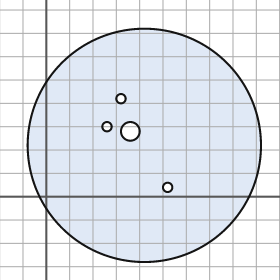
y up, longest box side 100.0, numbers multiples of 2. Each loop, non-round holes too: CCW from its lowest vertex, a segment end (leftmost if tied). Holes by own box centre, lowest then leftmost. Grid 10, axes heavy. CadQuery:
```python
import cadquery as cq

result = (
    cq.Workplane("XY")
    .moveTo(42.0, 22.0)
    .circle(50.0)
    .moveTo(52.0, 4.0)
    .circle(2.0)
    .moveTo(36.0, 28.0)
    .circle(4.0)
    .moveTo(26.0, 30.0)
    .circle(2.0)
    .moveTo(32.0, 42.0)
    .circle(2.0)
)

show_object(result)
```